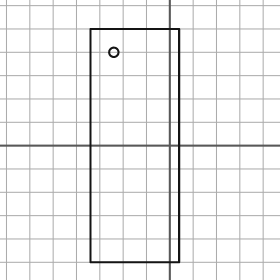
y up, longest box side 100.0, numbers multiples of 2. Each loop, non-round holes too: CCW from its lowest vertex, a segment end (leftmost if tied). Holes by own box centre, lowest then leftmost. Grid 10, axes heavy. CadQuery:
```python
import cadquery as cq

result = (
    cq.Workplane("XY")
    .moveTo(-34.0, -50.0)
    .lineTo(4.0, -50.0)
    .lineTo(4.0, 50.0)
    .lineTo(-34.0, 50.0)
    .close()
    .moveTo(-24.0, 40.0)
    .circle(2.0)
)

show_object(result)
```